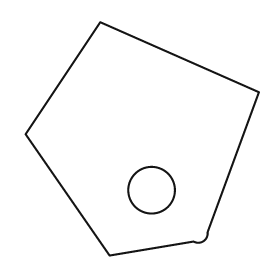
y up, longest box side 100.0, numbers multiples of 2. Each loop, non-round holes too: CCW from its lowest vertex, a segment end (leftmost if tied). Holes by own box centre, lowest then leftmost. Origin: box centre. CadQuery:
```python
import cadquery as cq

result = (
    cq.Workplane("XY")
    .moveTo(-14.0, -50.0)
    .lineTo(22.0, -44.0)
    .threePointArc((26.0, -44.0), (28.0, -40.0))
    .lineTo(50.0, 20.0)
    .lineTo(-18.0, 50.0)
    .lineTo(-50.0, 2.0)
    .close()
    .moveTo(4.0, -22.0)
    .circle(10.0)
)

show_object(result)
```